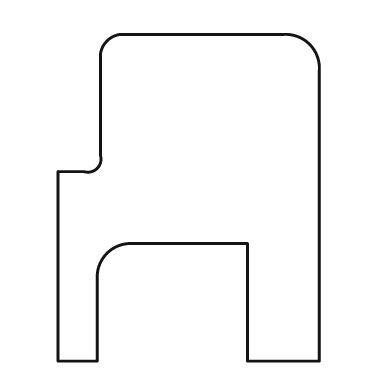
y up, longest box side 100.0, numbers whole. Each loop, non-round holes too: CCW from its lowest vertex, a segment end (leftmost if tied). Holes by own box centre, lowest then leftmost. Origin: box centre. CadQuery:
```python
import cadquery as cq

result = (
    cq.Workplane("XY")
    .moveTo(-40.0, -50.0)
    .lineTo(-28.0, -50.0)
    .lineTo(-28.0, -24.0)
    .threePointArc((-25.0, -17.0), (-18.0, -14.0))
    .lineTo(18.0, -14.0)
    .lineTo(18.0, -50.0)
    .lineTo(40.0, -50.0)
    .lineTo(40.0, 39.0)
    .threePointArc((37.0, 47.0), (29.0, 50.0))
    .lineTo(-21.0, 50.0)
    .threePointArc((-25.0, 48.0), (-27.0, 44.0))
    .lineTo(-27.0, 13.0)
    .threePointArc((-28.0, 9.0), (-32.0, 8.0))
    .lineTo(-40.0, 8.0)
    .close()
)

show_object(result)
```